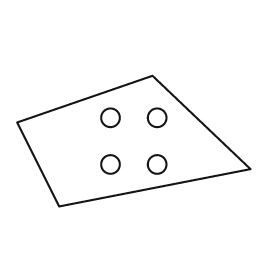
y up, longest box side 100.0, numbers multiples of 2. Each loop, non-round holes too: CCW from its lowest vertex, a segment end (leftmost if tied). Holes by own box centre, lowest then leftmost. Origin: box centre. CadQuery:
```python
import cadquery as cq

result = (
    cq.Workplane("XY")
    .moveTo(-32.0, -28.0)
    .lineTo(50.0, -12.0)
    .lineTo(8.0, 28.0)
    .lineTo(-50.0, 8.0)
    .close()
    .moveTo(-10.0, -10.0)
    .circle(4.0)
    .moveTo(10.0, -10.0)
    .circle(4.0)
    .moveTo(-10.0, 10.0)
    .circle(4.0)
    .moveTo(10.0, 10.0)
    .circle(4.0)
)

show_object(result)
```